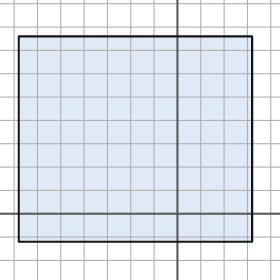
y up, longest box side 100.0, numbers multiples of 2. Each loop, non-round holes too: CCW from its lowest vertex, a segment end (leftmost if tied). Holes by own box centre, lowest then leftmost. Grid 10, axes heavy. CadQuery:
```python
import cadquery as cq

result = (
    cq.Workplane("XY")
    .moveTo(-68.0, -12.0)
    .lineTo(32.0, -12.0)
    .lineTo(32.0, 76.0)
    .lineTo(-68.0, 76.0)
    .close()
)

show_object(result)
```